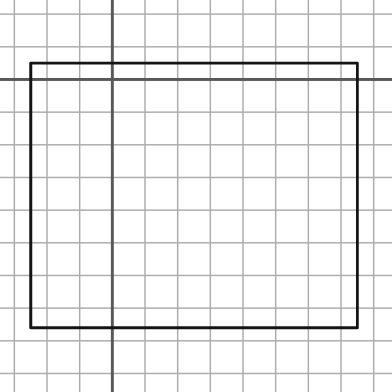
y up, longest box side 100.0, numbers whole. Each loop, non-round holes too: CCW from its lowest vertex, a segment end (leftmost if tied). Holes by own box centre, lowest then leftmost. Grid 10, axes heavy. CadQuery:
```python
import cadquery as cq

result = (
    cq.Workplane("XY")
    .moveTo(-25.0, -76.0)
    .lineTo(75.0, -76.0)
    .lineTo(75.0, 5.0)
    .lineTo(-25.0, 5.0)
    .close()
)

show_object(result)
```